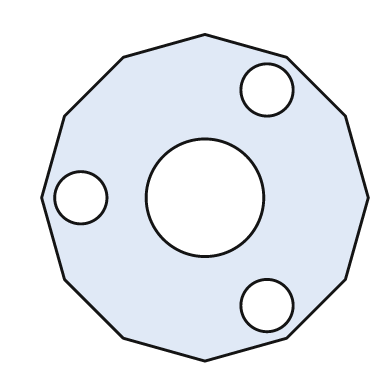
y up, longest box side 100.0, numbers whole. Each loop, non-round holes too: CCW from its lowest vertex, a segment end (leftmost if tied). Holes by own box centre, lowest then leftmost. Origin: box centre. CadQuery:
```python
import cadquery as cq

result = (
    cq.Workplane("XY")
    .moveTo(0.0, -50.0)
    .lineTo(25.0, -43.0)
    .lineTo(43.0, -25.0)
    .lineTo(50.0, 0.0)
    .lineTo(43.0, 25.0)
    .lineTo(25.0, 43.0)
    .lineTo(0.0, 50.0)
    .lineTo(-25.0, 43.0)
    .lineTo(-43.0, 25.0)
    .lineTo(-50.0, 0.0)
    .lineTo(-43.0, -25.0)
    .lineTo(-25.0, -43.0)
    .close()
    .moveTo(19.0, -33.0)
    .circle(8.0)
    .moveTo(-38.0, 0.0)
    .circle(8.0)
    .moveTo(0.0, 0.0)
    .circle(18.0)
    .moveTo(19.0, 33.0)
    .circle(8.0)
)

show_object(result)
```